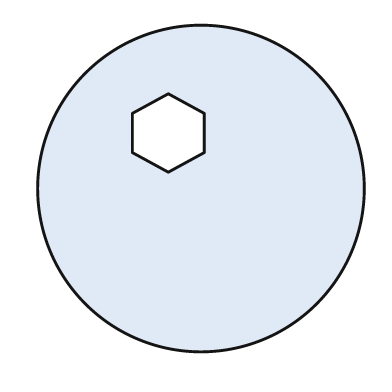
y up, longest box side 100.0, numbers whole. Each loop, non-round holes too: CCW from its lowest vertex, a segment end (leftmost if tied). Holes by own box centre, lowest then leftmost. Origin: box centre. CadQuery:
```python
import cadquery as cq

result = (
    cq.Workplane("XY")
    .moveTo(0.0, 0.0)
    .circle(50.0)
    .moveTo(-10.0, 5.0)
    .lineTo(1.0, 11.0)
    .lineTo(1.0, 23.0)
    .lineTo(-10.0, 29.0)
    .lineTo(-21.0, 23.0)
    .lineTo(-21.0, 11.0)
    .close()
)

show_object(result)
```